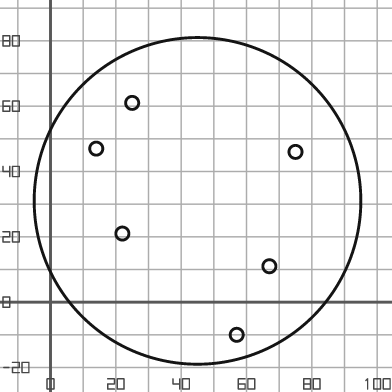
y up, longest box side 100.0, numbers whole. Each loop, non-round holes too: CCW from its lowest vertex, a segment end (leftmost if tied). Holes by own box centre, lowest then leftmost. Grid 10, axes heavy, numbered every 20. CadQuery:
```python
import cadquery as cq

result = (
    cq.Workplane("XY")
    .moveTo(45.0, 31.0)
    .circle(50.0)
    .moveTo(57.0, -10.0)
    .circle(2.0)
    .moveTo(67.0, 11.0)
    .circle(2.0)
    .moveTo(22.0, 21.0)
    .circle(2.0)
    .moveTo(75.0, 46.0)
    .circle(2.0)
    .moveTo(14.0, 47.0)
    .circle(2.0)
    .moveTo(25.0, 61.0)
    .circle(2.0)
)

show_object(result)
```